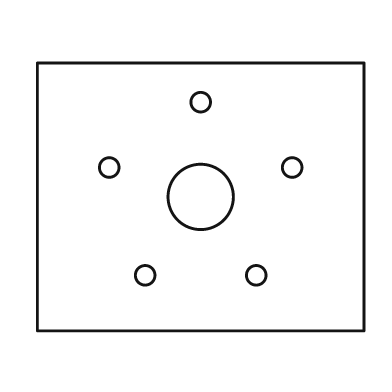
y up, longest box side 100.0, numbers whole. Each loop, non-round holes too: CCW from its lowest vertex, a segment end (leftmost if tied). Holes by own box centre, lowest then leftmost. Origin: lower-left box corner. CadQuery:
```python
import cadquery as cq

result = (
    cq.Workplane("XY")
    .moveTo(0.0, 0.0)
    .lineTo(100.0, 0.0)
    .lineTo(100.0, 82.0)
    .lineTo(0.0, 82.0)
    .close()
    .moveTo(33.0, 17.0)
    .circle(3.0)
    .moveTo(67.0, 17.0)
    .circle(3.0)
    .moveTo(50.0, 41.0)
    .circle(10.0)
    .moveTo(22.0, 50.0)
    .circle(3.0)
    .moveTo(78.0, 50.0)
    .circle(3.0)
    .moveTo(50.0, 70.0)
    .circle(3.0)
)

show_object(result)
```